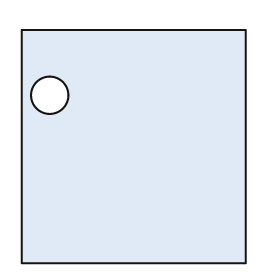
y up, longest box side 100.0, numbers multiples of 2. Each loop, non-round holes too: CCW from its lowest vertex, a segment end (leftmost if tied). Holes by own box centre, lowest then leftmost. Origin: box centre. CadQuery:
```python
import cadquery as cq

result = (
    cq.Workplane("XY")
    .moveTo(-48.0, -50.0)
    .lineTo(48.0, -50.0)
    .lineTo(48.0, 50.0)
    .lineTo(-48.0, 50.0)
    .close()
    .moveTo(-36.0, 22.0)
    .circle(8.0)
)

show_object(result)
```